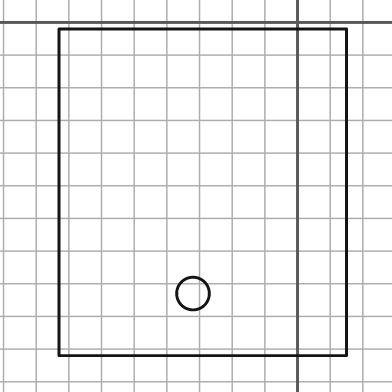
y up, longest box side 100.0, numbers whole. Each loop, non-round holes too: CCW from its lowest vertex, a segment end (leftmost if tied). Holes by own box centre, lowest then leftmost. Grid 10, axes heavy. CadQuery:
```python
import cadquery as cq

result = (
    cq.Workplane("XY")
    .moveTo(-73.0, -102.0)
    .lineTo(15.0, -102.0)
    .lineTo(15.0, -2.0)
    .lineTo(-73.0, -2.0)
    .close()
    .moveTo(-32.0, -83.0)
    .circle(5.0)
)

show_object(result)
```